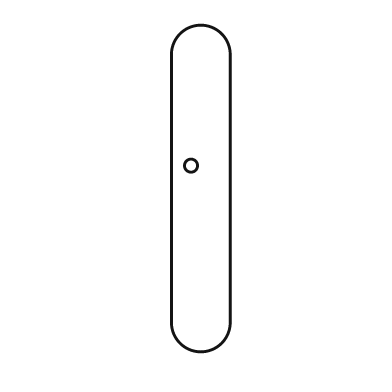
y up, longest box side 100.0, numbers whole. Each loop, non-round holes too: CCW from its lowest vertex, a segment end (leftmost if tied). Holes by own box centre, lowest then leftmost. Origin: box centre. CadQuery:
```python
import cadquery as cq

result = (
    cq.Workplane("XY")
    .moveTo(-9.0, -41.0)
    .threePointArc((0.0, -50.0), (9.0, -41.0))
    .lineTo(9.0, 41.0)
    .threePointArc((0.0, 50.0), (-9.0, 41.0))
    .close()
    .moveTo(-3.0, 7.0)
    .circle(2.0)
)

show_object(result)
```